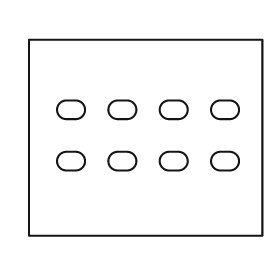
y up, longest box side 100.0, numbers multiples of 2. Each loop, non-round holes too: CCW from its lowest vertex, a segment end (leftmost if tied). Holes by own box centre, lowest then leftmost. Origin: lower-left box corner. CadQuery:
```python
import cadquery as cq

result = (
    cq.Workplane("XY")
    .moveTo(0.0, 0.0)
    .lineTo(100.0, 0.0)
    .lineTo(100.0, 84.0)
    .lineTo(0.0, 84.0)
    .close()
    .moveTo(16.0, 28.0)
    .lineTo(20.0, 28.0)
    .threePointArc((24.0, 32.0), (20.0, 36.0))
    .lineTo(16.0, 36.0)
    .threePointArc((12.0, 32.0), (16.0, 28.0))
    .close()
    .moveTo(38.0, 28.0)
    .lineTo(42.0, 28.0)
    .threePointArc((46.0, 32.0), (42.0, 36.0))
    .lineTo(38.0, 36.0)
    .threePointArc((34.0, 32.0), (38.0, 28.0))
    .close()
    .moveTo(60.0, 28.0)
    .lineTo(64.0, 28.0)
    .threePointArc((68.0, 32.0), (64.0, 36.0))
    .lineTo(60.0, 36.0)
    .threePointArc((56.0, 32.0), (60.0, 28.0))
    .close()
    .moveTo(82.0, 28.0)
    .lineTo(86.0, 28.0)
    .threePointArc((90.0, 32.0), (86.0, 36.0))
    .lineTo(82.0, 36.0)
    .threePointArc((78.0, 32.0), (82.0, 28.0))
    .close()
    .moveTo(16.0, 50.0)
    .lineTo(20.0, 50.0)
    .threePointArc((24.0, 54.0), (20.0, 58.0))
    .lineTo(16.0, 58.0)
    .threePointArc((12.0, 54.0), (16.0, 50.0))
    .close()
    .moveTo(38.0, 50.0)
    .lineTo(42.0, 50.0)
    .threePointArc((46.0, 54.0), (42.0, 58.0))
    .lineTo(38.0, 58.0)
    .threePointArc((34.0, 54.0), (38.0, 50.0))
    .close()
    .moveTo(60.0, 50.0)
    .lineTo(64.0, 50.0)
    .threePointArc((68.0, 54.0), (64.0, 58.0))
    .lineTo(60.0, 58.0)
    .threePointArc((56.0, 54.0), (60.0, 50.0))
    .close()
    .moveTo(82.0, 50.0)
    .lineTo(86.0, 50.0)
    .threePointArc((90.0, 54.0), (86.0, 58.0))
    .lineTo(82.0, 58.0)
    .threePointArc((78.0, 54.0), (82.0, 50.0))
    .close()
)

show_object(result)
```